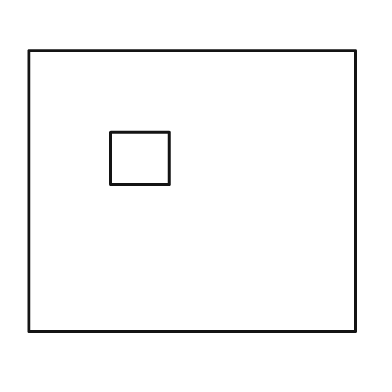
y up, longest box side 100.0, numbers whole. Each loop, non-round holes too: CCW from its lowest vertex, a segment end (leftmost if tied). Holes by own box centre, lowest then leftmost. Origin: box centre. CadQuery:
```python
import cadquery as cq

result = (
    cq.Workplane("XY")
    .moveTo(-50.0, -43.0)
    .lineTo(50.0, -43.0)
    .lineTo(50.0, 43.0)
    .lineTo(-50.0, 43.0)
    .close()
    .moveTo(-25.0, 2.0)
    .lineTo(-7.0, 2.0)
    .lineTo(-7.0, 18.0)
    .lineTo(-25.0, 18.0)
    .close()
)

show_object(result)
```